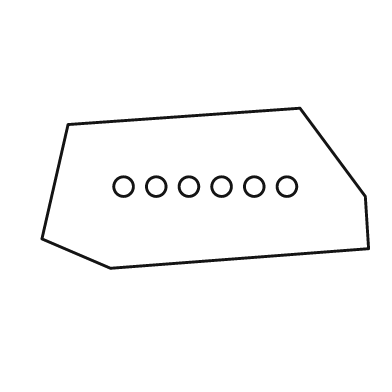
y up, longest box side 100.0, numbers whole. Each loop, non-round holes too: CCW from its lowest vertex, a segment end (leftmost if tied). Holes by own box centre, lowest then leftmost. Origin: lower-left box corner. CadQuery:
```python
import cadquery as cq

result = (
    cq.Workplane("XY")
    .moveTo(21.0, 0.0)
    .lineTo(100.0, 6.0)
    .lineTo(99.0, 22.0)
    .lineTo(79.0, 49.0)
    .lineTo(8.0, 44.0)
    .lineTo(0.0, 9.0)
    .close()
    .moveTo(25.0, 25.0)
    .circle(3.0)
    .moveTo(35.0, 25.0)
    .circle(3.0)
    .moveTo(45.0, 25.0)
    .circle(3.0)
    .moveTo(55.0, 25.0)
    .circle(3.0)
    .moveTo(65.0, 25.0)
    .circle(3.0)
    .moveTo(75.0, 25.0)
    .circle(3.0)
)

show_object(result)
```